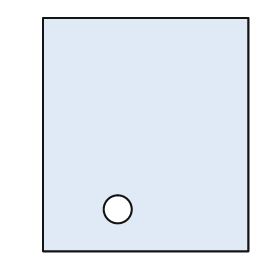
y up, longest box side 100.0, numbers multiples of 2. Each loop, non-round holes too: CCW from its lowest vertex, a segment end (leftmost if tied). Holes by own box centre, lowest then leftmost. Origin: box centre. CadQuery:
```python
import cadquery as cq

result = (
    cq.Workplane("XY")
    .moveTo(-44.0, -50.0)
    .lineTo(44.0, -50.0)
    .lineTo(44.0, 50.0)
    .lineTo(-44.0, 50.0)
    .close()
    .moveTo(-12.0, -32.0)
    .circle(6.0)
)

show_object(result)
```